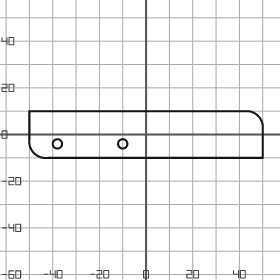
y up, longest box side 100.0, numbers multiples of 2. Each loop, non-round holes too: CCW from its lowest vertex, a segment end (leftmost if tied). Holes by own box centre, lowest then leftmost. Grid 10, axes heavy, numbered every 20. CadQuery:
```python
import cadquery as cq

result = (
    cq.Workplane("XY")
    .moveTo(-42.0, -10.0)
    .lineTo(50.0, -10.0)
    .lineTo(50.0, 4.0)
    .threePointArc((48.0, 8.0), (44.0, 10.0))
    .lineTo(-50.0, 10.0)
    .lineTo(-50.0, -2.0)
    .threePointArc((-48.0, -8.0), (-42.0, -10.0))
    .close()
    .moveTo(-38.0, -4.0)
    .circle(2.0)
    .moveTo(-10.0, -4.0)
    .circle(2.0)
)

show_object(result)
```